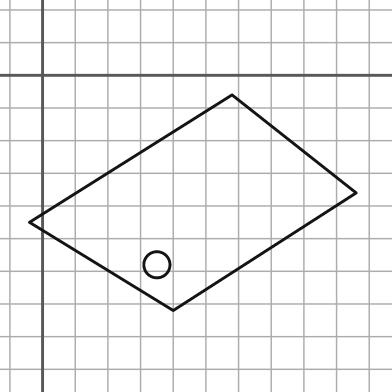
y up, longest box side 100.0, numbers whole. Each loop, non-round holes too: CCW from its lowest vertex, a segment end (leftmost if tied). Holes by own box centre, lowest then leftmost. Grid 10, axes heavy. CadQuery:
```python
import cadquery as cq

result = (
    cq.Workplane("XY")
    .moveTo(40.0, -72.0)
    .lineTo(96.0, -36.0)
    .lineTo(58.0, -6.0)
    .lineTo(-4.0, -45.0)
    .close()
    .moveTo(35.0, -58.0)
    .circle(4.0)
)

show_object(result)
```